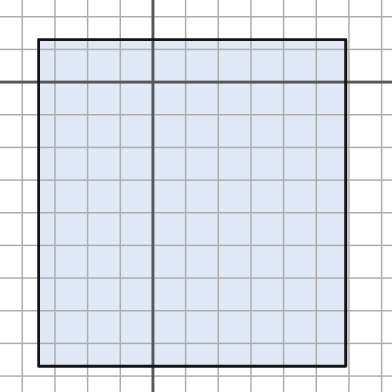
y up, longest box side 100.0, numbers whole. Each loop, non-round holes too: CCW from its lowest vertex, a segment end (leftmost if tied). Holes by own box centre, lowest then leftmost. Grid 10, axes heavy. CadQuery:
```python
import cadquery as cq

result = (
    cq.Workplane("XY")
    .moveTo(-35.0, -87.0)
    .lineTo(59.0, -87.0)
    .lineTo(59.0, 13.0)
    .lineTo(-35.0, 13.0)
    .close()
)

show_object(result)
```